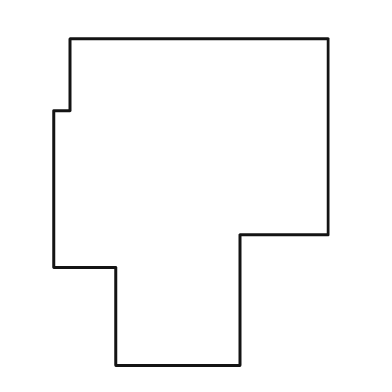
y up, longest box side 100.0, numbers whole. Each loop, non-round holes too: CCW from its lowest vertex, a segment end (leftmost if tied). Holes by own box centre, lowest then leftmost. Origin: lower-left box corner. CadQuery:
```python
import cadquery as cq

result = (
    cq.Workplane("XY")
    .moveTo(19.0, 0.0)
    .lineTo(57.0, 0.0)
    .lineTo(57.0, 40.0)
    .lineTo(84.0, 40.0)
    .lineTo(84.0, 100.0)
    .lineTo(5.0, 100.0)
    .lineTo(5.0, 78.0)
    .lineTo(0.0, 78.0)
    .lineTo(0.0, 30.0)
    .lineTo(19.0, 30.0)
    .close()
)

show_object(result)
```